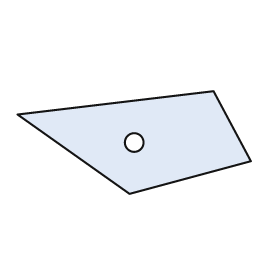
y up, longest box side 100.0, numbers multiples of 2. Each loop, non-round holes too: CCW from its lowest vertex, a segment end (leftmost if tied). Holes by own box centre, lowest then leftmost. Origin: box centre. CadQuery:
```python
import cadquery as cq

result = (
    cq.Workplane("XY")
    .moveTo(-2.0, -22.0)
    .lineTo(50.0, -8.0)
    .lineTo(34.0, 22.0)
    .lineTo(-50.0, 12.0)
    .close()
    .moveTo(0.0, 0.0)
    .circle(4.0)
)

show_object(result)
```